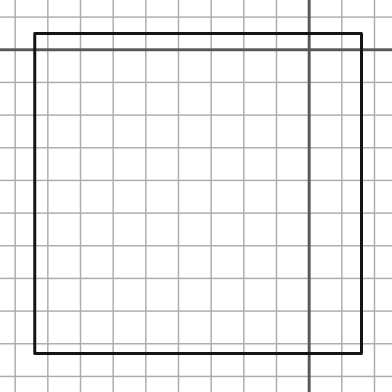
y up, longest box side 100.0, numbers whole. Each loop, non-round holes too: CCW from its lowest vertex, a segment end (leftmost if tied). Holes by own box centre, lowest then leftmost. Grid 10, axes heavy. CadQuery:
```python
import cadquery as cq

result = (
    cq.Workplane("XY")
    .moveTo(-84.0, -93.0)
    .lineTo(16.0, -93.0)
    .lineTo(16.0, 5.0)
    .lineTo(-84.0, 5.0)
    .close()
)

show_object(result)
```